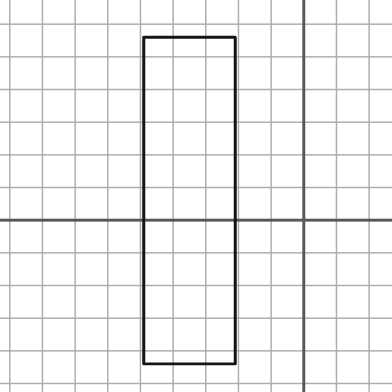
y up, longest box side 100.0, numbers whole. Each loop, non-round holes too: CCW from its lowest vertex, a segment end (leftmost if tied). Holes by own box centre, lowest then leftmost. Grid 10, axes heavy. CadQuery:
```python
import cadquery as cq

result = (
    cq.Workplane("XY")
    .moveTo(-49.0, -44.0)
    .lineTo(-21.0, -44.0)
    .lineTo(-21.0, 56.0)
    .lineTo(-49.0, 56.0)
    .close()
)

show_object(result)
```